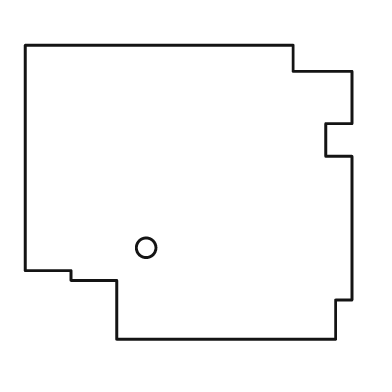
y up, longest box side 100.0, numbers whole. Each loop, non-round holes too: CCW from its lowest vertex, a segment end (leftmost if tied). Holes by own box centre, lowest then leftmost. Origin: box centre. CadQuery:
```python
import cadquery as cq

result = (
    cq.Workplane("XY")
    .moveTo(-22.0, -45.0)
    .lineTo(45.0, -45.0)
    .lineTo(45.0, -33.0)
    .lineTo(50.0, -33.0)
    .lineTo(50.0, 11.0)
    .lineTo(42.0, 11.0)
    .lineTo(42.0, 21.0)
    .lineTo(50.0, 21.0)
    .lineTo(50.0, 37.0)
    .lineTo(32.0, 37.0)
    .lineTo(32.0, 45.0)
    .lineTo(-50.0, 45.0)
    .lineTo(-50.0, -24.0)
    .lineTo(-36.0, -24.0)
    .lineTo(-36.0, -27.0)
    .lineTo(-22.0, -27.0)
    .close()
    .moveTo(-13.0, -17.0)
    .circle(3.0)
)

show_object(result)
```